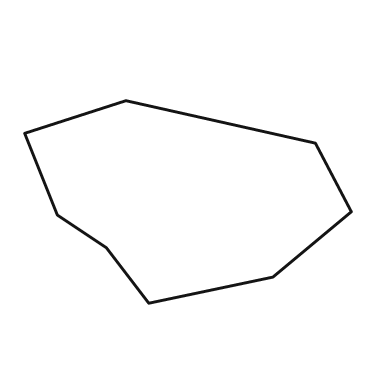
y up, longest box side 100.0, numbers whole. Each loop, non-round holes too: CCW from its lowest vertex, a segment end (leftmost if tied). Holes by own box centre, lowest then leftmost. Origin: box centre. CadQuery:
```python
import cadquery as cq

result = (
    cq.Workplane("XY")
    .moveTo(-12.0, -31.0)
    .lineTo(26.0, -23.0)
    .lineTo(50.0, -3.0)
    .lineTo(39.0, 18.0)
    .lineTo(-19.0, 31.0)
    .lineTo(-50.0, 21.0)
    .lineTo(-40.0, -4.0)
    .lineTo(-25.0, -14.0)
    .close()
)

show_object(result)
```